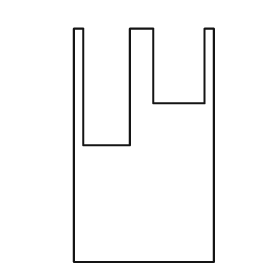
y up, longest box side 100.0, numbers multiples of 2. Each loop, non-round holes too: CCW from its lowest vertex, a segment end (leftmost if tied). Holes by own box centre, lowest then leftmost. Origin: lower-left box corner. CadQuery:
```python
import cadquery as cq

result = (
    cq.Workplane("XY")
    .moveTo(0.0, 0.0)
    .lineTo(60.0, 0.0)
    .lineTo(60.0, 100.0)
    .lineTo(56.0, 100.0)
    .lineTo(56.0, 68.0)
    .lineTo(34.0, 68.0)
    .lineTo(34.0, 100.0)
    .lineTo(24.0, 100.0)
    .lineTo(24.0, 50.0)
    .lineTo(4.0, 50.0)
    .lineTo(4.0, 100.0)
    .lineTo(0.0, 100.0)
    .close()
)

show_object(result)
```